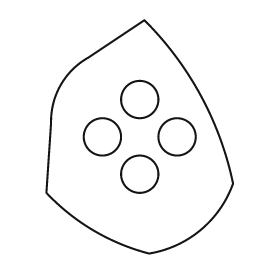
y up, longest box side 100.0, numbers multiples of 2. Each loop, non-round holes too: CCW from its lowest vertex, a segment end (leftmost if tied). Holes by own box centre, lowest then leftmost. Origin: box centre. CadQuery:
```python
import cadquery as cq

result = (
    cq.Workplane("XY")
    .moveTo(4.0, -50.0)
    .threePointArc((26.0, -40.0), (40.0, -20.0))
    .threePointArc((26.0, 18.0), (2.0, 50.0))
    .lineTo(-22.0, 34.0)
    .threePointArc((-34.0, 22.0), (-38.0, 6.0))
    .lineTo(-40.0, -24.0)
    .threePointArc((-20.0, -40.0), (4.0, -50.0))
    .close()
    .moveTo(0.0, -16.0)
    .circle(8.0)
    .moveTo(-16.0, 0.0)
    .circle(8.0)
    .moveTo(16.0, 0.0)
    .circle(8.0)
    .moveTo(0.0, 16.0)
    .circle(8.0)
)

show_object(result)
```